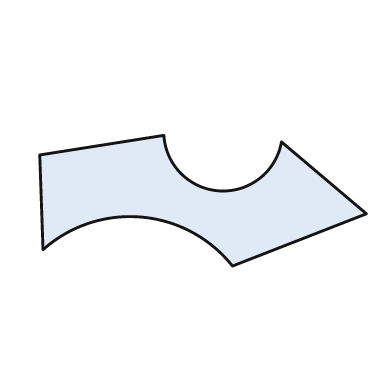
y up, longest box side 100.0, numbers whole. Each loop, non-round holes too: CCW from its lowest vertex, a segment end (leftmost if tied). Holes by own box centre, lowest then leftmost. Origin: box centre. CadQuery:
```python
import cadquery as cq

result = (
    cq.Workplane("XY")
    .moveTo(9.0, -20.0)
    .lineTo(50.0, -4.0)
    .lineTo(24.0, 18.0)
    .threePointArc((5.0, 3.0), (-12.0, 20.0))
    .lineTo(-50.0, 14.0)
    .lineTo(-49.0, -15.0)
    .threePointArc((-19.0, -5.0), (9.0, -20.0))
    .close()
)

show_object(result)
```